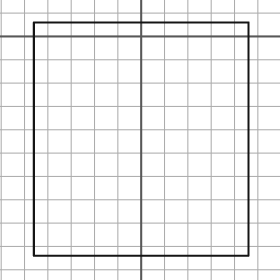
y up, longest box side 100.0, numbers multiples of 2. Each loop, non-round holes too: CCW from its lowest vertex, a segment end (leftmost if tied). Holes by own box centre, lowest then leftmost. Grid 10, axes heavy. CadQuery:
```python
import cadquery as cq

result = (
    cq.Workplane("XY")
    .moveTo(-46.0, -94.0)
    .lineTo(46.0, -94.0)
    .lineTo(46.0, 6.0)
    .lineTo(-46.0, 6.0)
    .close()
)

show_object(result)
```